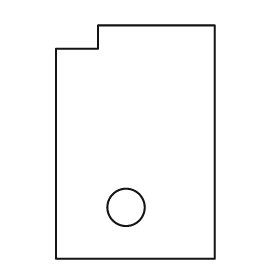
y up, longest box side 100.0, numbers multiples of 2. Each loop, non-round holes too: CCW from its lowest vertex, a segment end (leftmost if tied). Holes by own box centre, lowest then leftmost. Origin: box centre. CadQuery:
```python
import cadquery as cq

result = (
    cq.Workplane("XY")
    .moveTo(-34.0, -50.0)
    .lineTo(34.0, -50.0)
    .lineTo(34.0, 50.0)
    .lineTo(-16.0, 50.0)
    .lineTo(-16.0, 40.0)
    .lineTo(-34.0, 40.0)
    .close()
    .moveTo(-4.0, -28.0)
    .circle(8.0)
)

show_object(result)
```